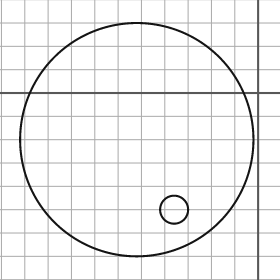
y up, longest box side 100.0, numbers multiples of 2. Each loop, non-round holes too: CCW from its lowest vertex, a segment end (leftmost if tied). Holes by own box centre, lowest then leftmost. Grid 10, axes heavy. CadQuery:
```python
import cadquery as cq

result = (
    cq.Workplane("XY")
    .moveTo(-52.0, -20.0)
    .circle(50.0)
    .moveTo(-36.0, -50.0)
    .circle(6.0)
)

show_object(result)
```